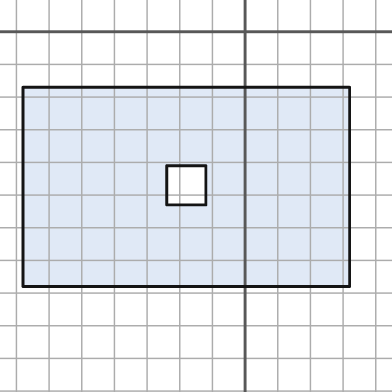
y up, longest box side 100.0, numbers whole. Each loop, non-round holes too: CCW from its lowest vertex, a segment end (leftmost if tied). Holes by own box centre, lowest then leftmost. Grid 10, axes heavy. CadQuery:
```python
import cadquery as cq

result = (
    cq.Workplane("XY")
    .moveTo(-68.0, -78.0)
    .lineTo(32.0, -78.0)
    .lineTo(32.0, -17.0)
    .lineTo(-68.0, -17.0)
    .close()
    .moveTo(-24.0, -53.0)
    .lineTo(-12.0, -53.0)
    .lineTo(-12.0, -41.0)
    .lineTo(-24.0, -41.0)
    .close()
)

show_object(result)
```